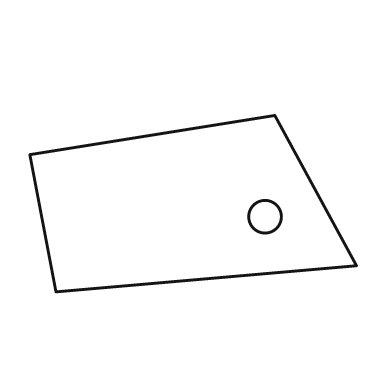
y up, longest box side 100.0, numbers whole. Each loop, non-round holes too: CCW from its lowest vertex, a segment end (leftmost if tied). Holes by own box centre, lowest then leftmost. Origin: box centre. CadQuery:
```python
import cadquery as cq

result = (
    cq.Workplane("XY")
    .moveTo(-42.0, -27.0)
    .lineTo(50.0, -19.0)
    .lineTo(25.0, 27.0)
    .lineTo(-50.0, 15.0)
    .close()
    .moveTo(22.0, -4.0)
    .circle(5.0)
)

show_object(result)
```